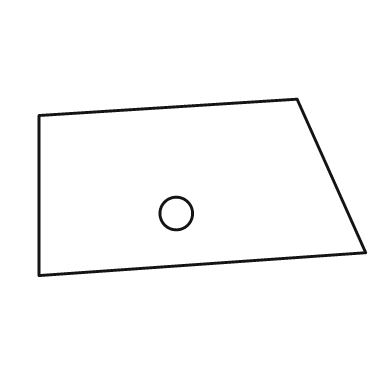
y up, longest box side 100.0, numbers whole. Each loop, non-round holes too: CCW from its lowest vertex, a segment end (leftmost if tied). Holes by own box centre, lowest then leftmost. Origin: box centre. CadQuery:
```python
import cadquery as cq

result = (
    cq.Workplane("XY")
    .moveTo(-50.0, -27.0)
    .lineTo(50.0, -20.0)
    .lineTo(29.0, 27.0)
    .lineTo(-50.0, 22.0)
    .close()
    .moveTo(-8.0, -8.0)
    .circle(5.0)
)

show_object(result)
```